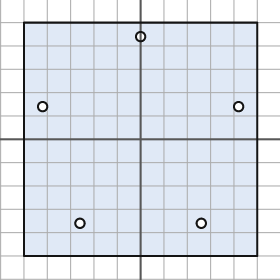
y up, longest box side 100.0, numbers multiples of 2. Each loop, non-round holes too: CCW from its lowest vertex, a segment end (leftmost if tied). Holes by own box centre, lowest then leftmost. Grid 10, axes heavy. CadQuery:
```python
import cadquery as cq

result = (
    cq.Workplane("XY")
    .moveTo(-50.0, -50.0)
    .lineTo(50.0, -50.0)
    .lineTo(50.0, 50.0)
    .lineTo(-50.0, 50.0)
    .close()
    .moveTo(-26.0, -36.0)
    .circle(2.0)
    .moveTo(26.0, -36.0)
    .circle(2.0)
    .moveTo(-42.0, 14.0)
    .circle(2.0)
    .moveTo(42.0, 14.0)
    .circle(2.0)
    .moveTo(0.0, 44.0)
    .circle(2.0)
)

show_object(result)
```